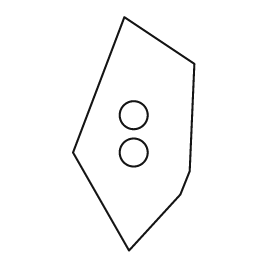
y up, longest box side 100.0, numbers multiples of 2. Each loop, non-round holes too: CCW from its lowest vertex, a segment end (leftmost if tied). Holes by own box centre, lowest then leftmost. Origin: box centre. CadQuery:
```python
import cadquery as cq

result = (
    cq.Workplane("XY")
    .moveTo(-2.0, -50.0)
    .lineTo(20.0, -26.0)
    .lineTo(24.0, -16.0)
    .lineTo(26.0, 30.0)
    .lineTo(-4.0, 50.0)
    .lineTo(-26.0, -8.0)
    .close()
    .moveTo(0.0, -8.0)
    .circle(6.0)
    .moveTo(0.0, 8.0)
    .circle(6.0)
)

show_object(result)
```